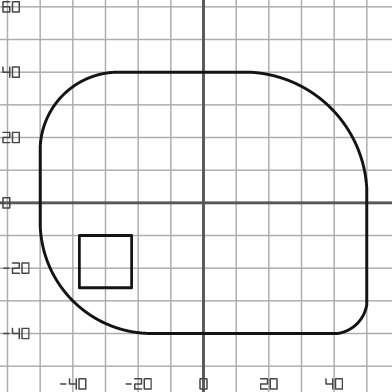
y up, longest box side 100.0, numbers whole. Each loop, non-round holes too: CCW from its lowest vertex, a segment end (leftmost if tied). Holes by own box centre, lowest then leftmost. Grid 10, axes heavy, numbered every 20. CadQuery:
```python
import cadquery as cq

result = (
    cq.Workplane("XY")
    .moveTo(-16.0, -40.0)
    .lineTo(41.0, -40.0)
    .threePointArc((47.0, -37.0), (50.0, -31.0))
    .lineTo(50.0, 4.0)
    .threePointArc((39.0, 29.0), (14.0, 40.0))
    .lineTo(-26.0, 40.0)
    .threePointArc((-43.0, 33.0), (-50.0, 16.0))
    .lineTo(-50.0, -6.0)
    .threePointArc((-40.0, -30.0), (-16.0, -40.0))
    .close()
    .moveTo(-38.0, -26.0)
    .lineTo(-22.0, -26.0)
    .lineTo(-22.0, -10.0)
    .lineTo(-38.0, -10.0)
    .close()
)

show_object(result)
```